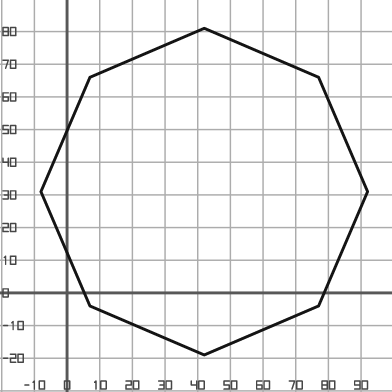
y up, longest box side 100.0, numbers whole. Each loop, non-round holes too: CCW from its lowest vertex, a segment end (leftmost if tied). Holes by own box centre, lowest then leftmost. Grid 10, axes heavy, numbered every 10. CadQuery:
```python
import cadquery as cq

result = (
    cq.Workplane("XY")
    .moveTo(42.0, -19.0)
    .lineTo(77.0, -4.0)
    .lineTo(92.0, 31.0)
    .lineTo(77.0, 66.0)
    .lineTo(42.0, 81.0)
    .lineTo(7.0, 66.0)
    .lineTo(-8.0, 31.0)
    .lineTo(7.0, -4.0)
    .close()
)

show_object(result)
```